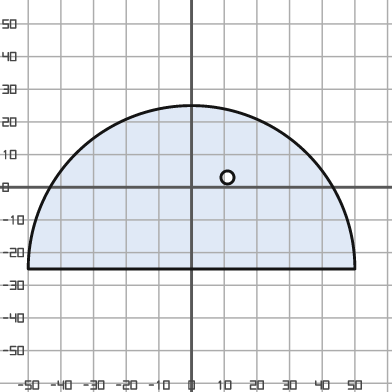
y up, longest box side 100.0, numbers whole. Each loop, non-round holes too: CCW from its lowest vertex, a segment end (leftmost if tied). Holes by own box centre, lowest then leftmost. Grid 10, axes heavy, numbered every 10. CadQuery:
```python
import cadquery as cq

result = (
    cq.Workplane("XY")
    .moveTo(-50.0, -25.0)
    .lineTo(50.0, -25.0)
    .threePointArc((0.0, 25.0), (-50.0, -25.0))
    .close()
    .moveTo(11.0, 3.0)
    .circle(2.0)
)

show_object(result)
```